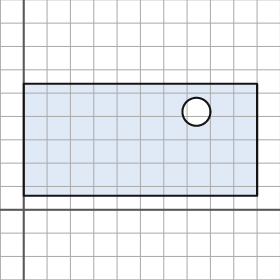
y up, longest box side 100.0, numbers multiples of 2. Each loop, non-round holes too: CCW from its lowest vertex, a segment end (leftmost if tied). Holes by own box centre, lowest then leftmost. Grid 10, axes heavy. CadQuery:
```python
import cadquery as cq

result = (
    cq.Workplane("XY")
    .moveTo(0.0, 6.0)
    .lineTo(100.0, 6.0)
    .lineTo(100.0, 54.0)
    .lineTo(0.0, 54.0)
    .close()
    .moveTo(74.0, 42.0)
    .circle(6.0)
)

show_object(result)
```